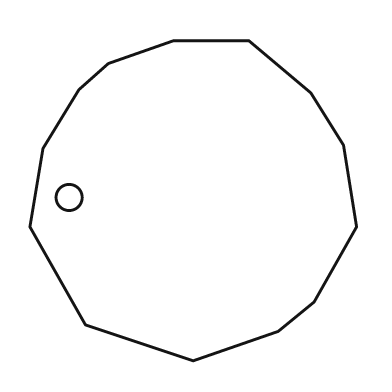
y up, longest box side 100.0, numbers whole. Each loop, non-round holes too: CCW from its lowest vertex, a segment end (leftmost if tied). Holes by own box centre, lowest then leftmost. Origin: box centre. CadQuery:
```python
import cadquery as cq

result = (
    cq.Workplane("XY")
    .moveTo(0.0, -49.0)
    .lineTo(26.0, -40.0)
    .lineTo(37.0, -31.0)
    .lineTo(50.0, -8.0)
    .lineTo(46.0, 17.0)
    .lineTo(36.0, 33.0)
    .lineTo(17.0, 49.0)
    .lineTo(-6.0, 49.0)
    .lineTo(-26.0, 42.0)
    .lineTo(-35.0, 34.0)
    .lineTo(-46.0, 16.0)
    .lineTo(-50.0, -8.0)
    .lineTo(-33.0, -38.0)
    .close()
    .moveTo(-38.0, 1.0)
    .circle(4.0)
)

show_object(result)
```